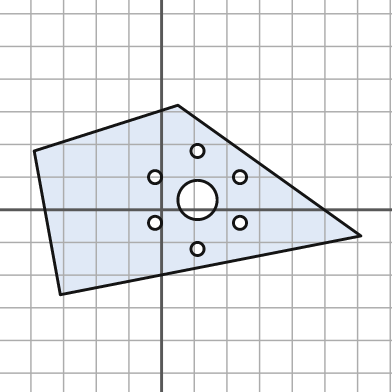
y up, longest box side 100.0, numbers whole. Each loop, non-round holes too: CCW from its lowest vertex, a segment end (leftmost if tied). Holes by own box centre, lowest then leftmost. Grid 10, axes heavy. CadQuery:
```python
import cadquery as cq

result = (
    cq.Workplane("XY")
    .moveTo(-31.0, -26.0)
    .lineTo(61.0, -8.0)
    .lineTo(5.0, 32.0)
    .lineTo(-39.0, 18.0)
    .close()
    .moveTo(11.0, -12.0)
    .circle(2.0)
    .moveTo(-2.0, -4.0)
    .circle(2.0)
    .moveTo(24.0, -4.0)
    .circle(2.0)
    .moveTo(11.0, 3.0)
    .circle(6.0)
    .moveTo(-2.0, 10.0)
    .circle(2.0)
    .moveTo(24.0, 10.0)
    .circle(2.0)
    .moveTo(11.0, 18.0)
    .circle(2.0)
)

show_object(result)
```